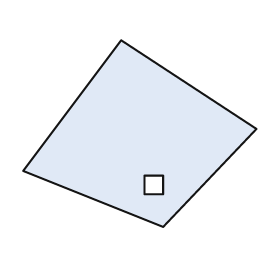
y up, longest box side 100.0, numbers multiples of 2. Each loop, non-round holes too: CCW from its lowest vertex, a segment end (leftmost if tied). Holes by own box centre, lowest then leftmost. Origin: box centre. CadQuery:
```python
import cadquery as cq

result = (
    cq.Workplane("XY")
    .moveTo(10.0, -40.0)
    .lineTo(50.0, 2.0)
    .lineTo(-8.0, 40.0)
    .lineTo(-50.0, -16.0)
    .close()
    .moveTo(2.0, -26.0)
    .lineTo(10.0, -26.0)
    .lineTo(10.0, -18.0)
    .lineTo(2.0, -18.0)
    .close()
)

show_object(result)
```